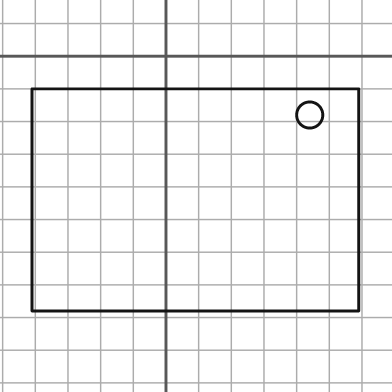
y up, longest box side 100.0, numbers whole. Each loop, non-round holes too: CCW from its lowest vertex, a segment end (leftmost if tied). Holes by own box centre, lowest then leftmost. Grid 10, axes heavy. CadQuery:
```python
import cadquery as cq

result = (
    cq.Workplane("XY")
    .moveTo(-41.0, -78.0)
    .lineTo(59.0, -78.0)
    .lineTo(59.0, -10.0)
    .lineTo(-41.0, -10.0)
    .close()
    .moveTo(44.0, -18.0)
    .circle(4.0)
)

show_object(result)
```